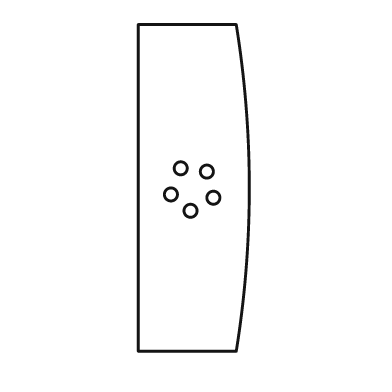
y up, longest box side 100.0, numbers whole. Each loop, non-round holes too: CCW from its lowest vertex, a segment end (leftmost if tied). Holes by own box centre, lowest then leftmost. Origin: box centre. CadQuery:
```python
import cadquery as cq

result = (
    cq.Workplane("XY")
    .moveTo(-17.0, -50.0)
    .lineTo(13.0, -50.0)
    .threePointArc((17.0, 0.0), (13.0, 50.0))
    .lineTo(-17.0, 50.0)
    .close()
    .moveTo(-1.0, -7.0)
    .circle(2.0)
    .moveTo(6.0, -3.0)
    .circle(2.0)
    .moveTo(-7.0, -2.0)
    .circle(2.0)
    .moveTo(4.0, 5.0)
    .circle(2.0)
    .moveTo(-4.0, 6.0)
    .circle(2.0)
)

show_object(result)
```